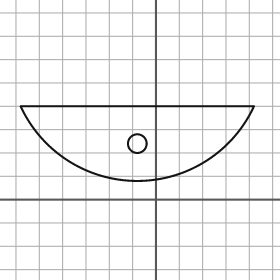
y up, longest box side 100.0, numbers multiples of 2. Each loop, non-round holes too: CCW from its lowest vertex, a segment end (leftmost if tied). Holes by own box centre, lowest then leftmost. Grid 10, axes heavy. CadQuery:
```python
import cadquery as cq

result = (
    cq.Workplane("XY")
    .moveTo(-58.0, 40.0)
    .threePointArc((-8.0, 8.0), (42.0, 40.0))
    .close()
    .moveTo(-8.0, 24.0)
    .circle(4.0)
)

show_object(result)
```